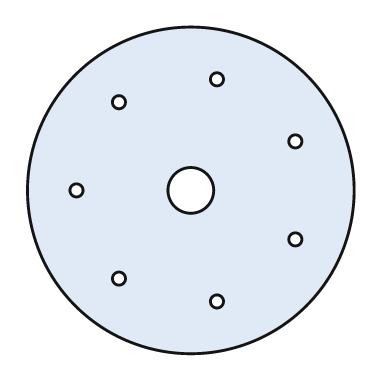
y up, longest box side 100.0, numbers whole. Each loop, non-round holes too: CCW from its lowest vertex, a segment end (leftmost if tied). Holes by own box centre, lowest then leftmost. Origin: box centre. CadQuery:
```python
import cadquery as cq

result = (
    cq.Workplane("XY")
    .moveTo(0.0, 0.0)
    .circle(50.0)
    .moveTo(8.0, -34.0)
    .circle(2.0)
    .moveTo(-22.0, -27.0)
    .circle(2.0)
    .moveTo(32.0, -15.0)
    .circle(2.0)
    .moveTo(-35.0, 0.0)
    .circle(2.0)
    .moveTo(0.0, 0.0)
    .circle(7.0)
    .moveTo(32.0, 15.0)
    .circle(2.0)
    .moveTo(-22.0, 27.0)
    .circle(2.0)
    .moveTo(8.0, 34.0)
    .circle(2.0)
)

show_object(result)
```